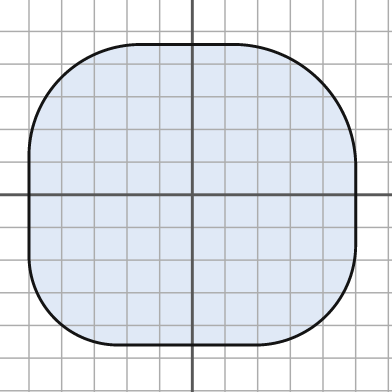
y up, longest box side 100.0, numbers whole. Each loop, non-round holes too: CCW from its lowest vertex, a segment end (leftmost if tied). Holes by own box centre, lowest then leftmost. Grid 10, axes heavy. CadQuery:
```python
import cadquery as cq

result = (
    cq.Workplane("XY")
    .moveTo(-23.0, -46.0)
    .lineTo(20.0, -46.0)
    .threePointArc((41.0, -37.0), (50.0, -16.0))
    .lineTo(50.0, 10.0)
    .threePointArc((39.0, 35.0), (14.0, 46.0))
    .lineTo(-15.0, 46.0)
    .threePointArc((-40.0, 36.0), (-50.0, 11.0))
    .lineTo(-50.0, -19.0)
    .threePointArc((-42.0, -38.0), (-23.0, -46.0))
    .close()
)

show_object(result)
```